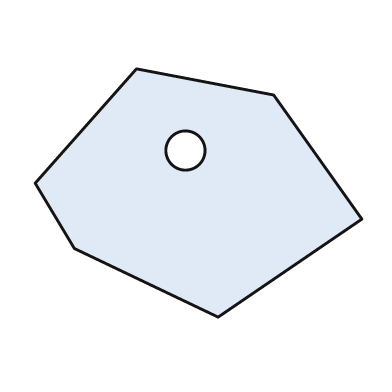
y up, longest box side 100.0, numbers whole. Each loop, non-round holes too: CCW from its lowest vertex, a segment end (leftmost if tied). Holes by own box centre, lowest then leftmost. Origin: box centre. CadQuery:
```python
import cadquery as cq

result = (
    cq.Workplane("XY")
    .moveTo(6.0, -38.0)
    .lineTo(50.0, -8.0)
    .lineTo(23.0, 30.0)
    .lineTo(-19.0, 38.0)
    .lineTo(-50.0, 3.0)
    .lineTo(-38.0, -17.0)
    .close()
    .moveTo(-4.0, 13.0)
    .circle(6.0)
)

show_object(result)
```